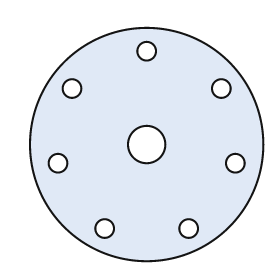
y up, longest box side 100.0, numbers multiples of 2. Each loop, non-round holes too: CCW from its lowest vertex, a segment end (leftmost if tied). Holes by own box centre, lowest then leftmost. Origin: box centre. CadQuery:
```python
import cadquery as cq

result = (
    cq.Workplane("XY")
    .moveTo(0.0, 0.0)
    .circle(50.0)
    .moveTo(-18.0, -36.0)
    .circle(4.0)
    .moveTo(18.0, -36.0)
    .circle(4.0)
    .moveTo(-38.0, -8.0)
    .circle(4.0)
    .moveTo(38.0, -8.0)
    .circle(4.0)
    .moveTo(0.0, 0.0)
    .circle(8.0)
    .moveTo(-32.0, 24.0)
    .circle(4.0)
    .moveTo(32.0, 24.0)
    .circle(4.0)
    .moveTo(0.0, 40.0)
    .circle(4.0)
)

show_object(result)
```